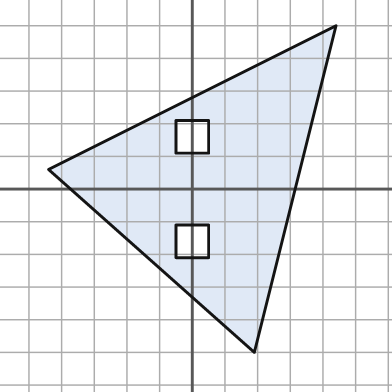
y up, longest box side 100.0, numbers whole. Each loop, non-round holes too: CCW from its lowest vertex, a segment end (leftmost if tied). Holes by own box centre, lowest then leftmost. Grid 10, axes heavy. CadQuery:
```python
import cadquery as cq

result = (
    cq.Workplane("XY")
    .moveTo(19.0, -50.0)
    .lineTo(44.0, 50.0)
    .lineTo(-44.0, 6.0)
    .close()
    .moveTo(-5.0, -21.0)
    .lineTo(5.0, -21.0)
    .lineTo(5.0, -11.0)
    .lineTo(-5.0, -11.0)
    .close()
    .moveTo(-5.0, 11.0)
    .lineTo(5.0, 11.0)
    .lineTo(5.0, 21.0)
    .lineTo(-5.0, 21.0)
    .close()
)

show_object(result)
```